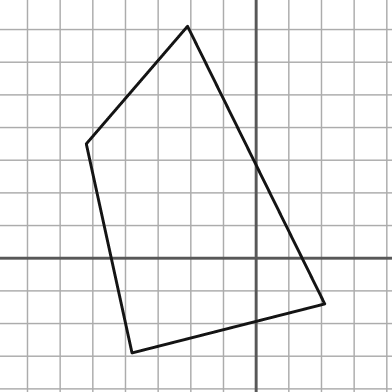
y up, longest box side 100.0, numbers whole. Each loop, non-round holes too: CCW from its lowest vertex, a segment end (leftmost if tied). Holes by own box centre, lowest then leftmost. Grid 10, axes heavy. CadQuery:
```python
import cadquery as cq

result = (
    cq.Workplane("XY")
    .moveTo(-38.0, -29.0)
    .lineTo(21.0, -14.0)
    .lineTo(-21.0, 71.0)
    .lineTo(-52.0, 35.0)
    .close()
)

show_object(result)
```